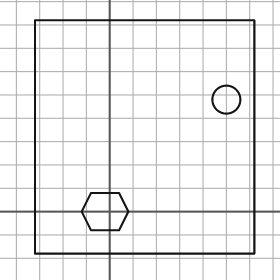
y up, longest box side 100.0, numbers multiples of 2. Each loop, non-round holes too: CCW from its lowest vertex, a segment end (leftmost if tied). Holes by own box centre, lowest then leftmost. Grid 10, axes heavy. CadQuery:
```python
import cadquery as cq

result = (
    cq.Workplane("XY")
    .moveTo(-32.0, -18.0)
    .lineTo(62.0, -18.0)
    .lineTo(62.0, 82.0)
    .lineTo(-32.0, 82.0)
    .close()
    .moveTo(-8.0, -8.0)
    .lineTo(4.0, -8.0)
    .lineTo(8.0, 0.0)
    .lineTo(4.0, 8.0)
    .lineTo(-8.0, 8.0)
    .lineTo(-12.0, 0.0)
    .close()
    .moveTo(50.0, 48.0)
    .circle(6.0)
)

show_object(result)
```